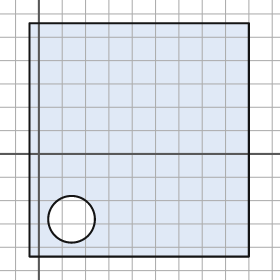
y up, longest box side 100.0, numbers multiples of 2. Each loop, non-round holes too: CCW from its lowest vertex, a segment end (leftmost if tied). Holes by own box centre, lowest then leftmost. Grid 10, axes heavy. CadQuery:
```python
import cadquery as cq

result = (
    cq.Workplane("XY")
    .moveTo(-4.0, -44.0)
    .lineTo(90.0, -44.0)
    .lineTo(90.0, 56.0)
    .lineTo(-4.0, 56.0)
    .close()
    .moveTo(14.0, -28.0)
    .circle(10.0)
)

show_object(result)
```